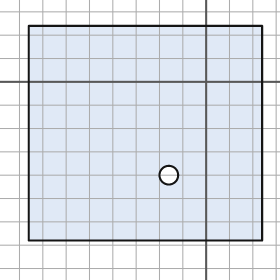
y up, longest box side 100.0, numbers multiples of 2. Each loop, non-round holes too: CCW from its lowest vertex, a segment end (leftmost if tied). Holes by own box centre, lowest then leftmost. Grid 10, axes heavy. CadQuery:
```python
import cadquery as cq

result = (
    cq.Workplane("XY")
    .moveTo(-76.0, -68.0)
    .lineTo(24.0, -68.0)
    .lineTo(24.0, 24.0)
    .lineTo(-76.0, 24.0)
    .close()
    .moveTo(-16.0, -40.0)
    .circle(4.0)
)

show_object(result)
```